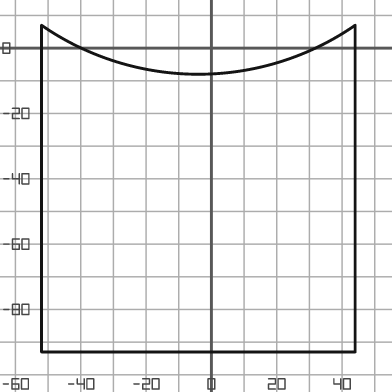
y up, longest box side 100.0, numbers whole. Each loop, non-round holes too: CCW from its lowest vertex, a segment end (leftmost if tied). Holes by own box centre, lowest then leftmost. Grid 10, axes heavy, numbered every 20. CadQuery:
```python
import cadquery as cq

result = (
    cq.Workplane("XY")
    .moveTo(-52.0, -93.0)
    .lineTo(44.0, -93.0)
    .lineTo(44.0, 7.0)
    .threePointArc((-4.0, -8.0), (-52.0, 7.0))
    .close()
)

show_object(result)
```